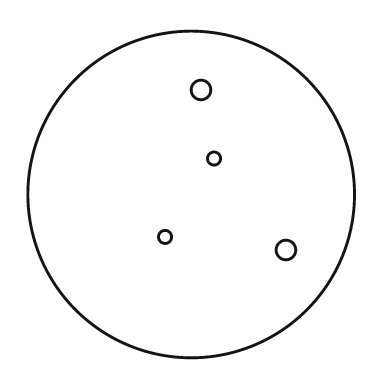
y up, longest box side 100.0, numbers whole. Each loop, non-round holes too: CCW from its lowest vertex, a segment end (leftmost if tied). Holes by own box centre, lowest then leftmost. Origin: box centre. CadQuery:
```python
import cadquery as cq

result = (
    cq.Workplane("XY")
    .moveTo(0.0, 0.0)
    .circle(50.0)
    .moveTo(29.0, -17.0)
    .circle(3.0)
    .moveTo(-8.0, -13.0)
    .circle(2.0)
    .moveTo(7.0, 11.0)
    .circle(2.0)
    .moveTo(3.0, 32.0)
    .circle(3.0)
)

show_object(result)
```